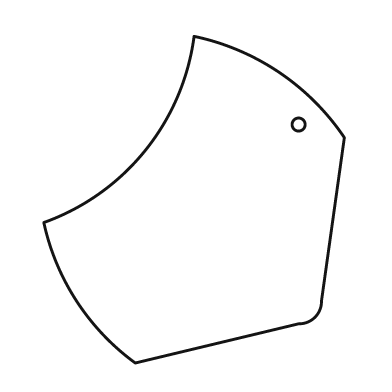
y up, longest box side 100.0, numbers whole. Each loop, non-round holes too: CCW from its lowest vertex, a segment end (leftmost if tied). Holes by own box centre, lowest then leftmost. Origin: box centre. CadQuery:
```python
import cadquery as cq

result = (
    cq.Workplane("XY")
    .moveTo(-18.0, -50.0)
    .lineTo(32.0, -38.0)
    .threePointArc((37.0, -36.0), (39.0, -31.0))
    .lineTo(46.0, 19.0)
    .threePointArc((26.0, 39.0), (0.0, 50.0))
    .threePointArc((-15.0, 15.0), (-46.0, -7.0))
    .threePointArc((-36.0, -31.0), (-18.0, -50.0))
    .close()
    .moveTo(32.0, 23.0)
    .circle(2.0)
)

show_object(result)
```